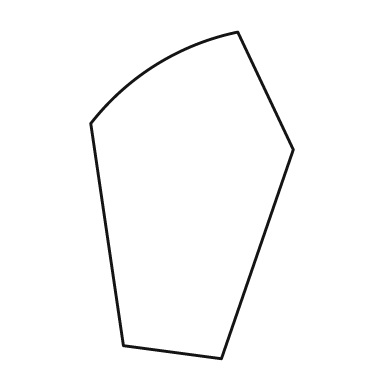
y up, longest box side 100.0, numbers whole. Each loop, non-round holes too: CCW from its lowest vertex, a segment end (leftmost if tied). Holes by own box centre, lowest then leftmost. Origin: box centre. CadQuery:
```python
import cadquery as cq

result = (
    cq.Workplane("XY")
    .moveTo(9.0, -50.0)
    .lineTo(31.0, 14.0)
    .lineTo(14.0, 50.0)
    .threePointArc((-11.0, 40.0), (-31.0, 22.0))
    .lineTo(-21.0, -46.0)
    .close()
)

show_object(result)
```